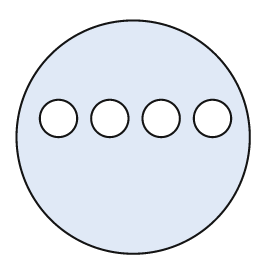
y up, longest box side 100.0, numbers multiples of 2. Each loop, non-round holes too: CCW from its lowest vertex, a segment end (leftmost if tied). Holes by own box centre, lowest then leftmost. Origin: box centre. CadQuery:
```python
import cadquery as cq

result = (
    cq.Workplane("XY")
    .moveTo(0.0, 0.0)
    .circle(50.0)
    .moveTo(-32.0, 8.0)
    .circle(8.0)
    .moveTo(-10.0, 8.0)
    .circle(8.0)
    .moveTo(12.0, 8.0)
    .circle(8.0)
    .moveTo(34.0, 8.0)
    .circle(8.0)
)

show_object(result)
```